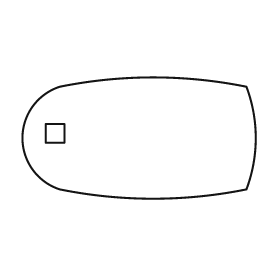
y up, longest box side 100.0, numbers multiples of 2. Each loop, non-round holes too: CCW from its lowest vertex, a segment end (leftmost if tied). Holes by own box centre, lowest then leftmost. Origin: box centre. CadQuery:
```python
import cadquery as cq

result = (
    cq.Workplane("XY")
    .moveTo(-34.0, -22.0)
    .threePointArc((6.0, -26.0), (46.0, -22.0))
    .threePointArc((50.0, 0.0), (46.0, 22.0))
    .threePointArc((6.0, 26.0), (-34.0, 22.0))
    .threePointArc((-50.0, 0.0), (-34.0, -22.0))
    .close()
    .moveTo(-40.0, -2.0)
    .lineTo(-32.0, -2.0)
    .lineTo(-32.0, 6.0)
    .lineTo(-40.0, 6.0)
    .close()
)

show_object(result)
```